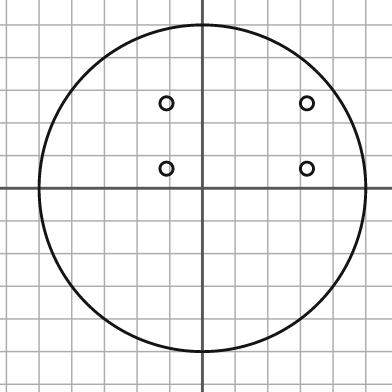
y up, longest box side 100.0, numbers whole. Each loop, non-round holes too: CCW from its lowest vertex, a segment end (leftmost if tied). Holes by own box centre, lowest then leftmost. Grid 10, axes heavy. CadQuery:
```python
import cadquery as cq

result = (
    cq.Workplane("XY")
    .moveTo(0.0, 0.0)
    .circle(50.0)
    .moveTo(-11.0, 6.0)
    .circle(2.0)
    .moveTo(32.0, 6.0)
    .circle(2.0)
    .moveTo(-11.0, 26.0)
    .circle(2.0)
    .moveTo(32.0, 26.0)
    .circle(2.0)
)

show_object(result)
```